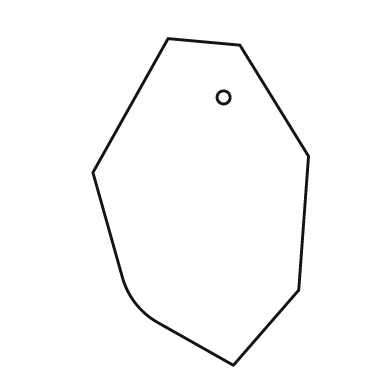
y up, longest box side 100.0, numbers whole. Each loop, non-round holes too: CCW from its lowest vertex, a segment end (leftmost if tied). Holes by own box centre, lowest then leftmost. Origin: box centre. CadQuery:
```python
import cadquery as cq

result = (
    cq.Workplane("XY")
    .moveTo(10.0, -50.0)
    .lineTo(30.0, -27.0)
    .lineTo(33.0, 14.0)
    .lineTo(12.0, 48.0)
    .lineTo(-10.0, 50.0)
    .lineTo(-33.0, 9.0)
    .lineTo(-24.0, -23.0)
    .threePointArc((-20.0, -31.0), (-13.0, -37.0))
    .close()
    .moveTo(7.0, 32.0)
    .circle(2.0)
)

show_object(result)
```